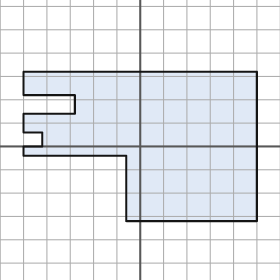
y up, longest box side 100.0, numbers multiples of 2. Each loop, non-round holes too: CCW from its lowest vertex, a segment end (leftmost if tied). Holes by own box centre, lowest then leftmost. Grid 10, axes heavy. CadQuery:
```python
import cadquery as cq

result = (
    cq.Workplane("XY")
    .moveTo(-6.0, -32.0)
    .lineTo(50.0, -32.0)
    .lineTo(50.0, 32.0)
    .lineTo(-50.0, 32.0)
    .lineTo(-50.0, 22.0)
    .lineTo(-28.0, 22.0)
    .lineTo(-28.0, 14.0)
    .lineTo(-50.0, 14.0)
    .lineTo(-50.0, 6.0)
    .lineTo(-42.0, 6.0)
    .lineTo(-42.0, 0.0)
    .lineTo(-50.0, 0.0)
    .lineTo(-50.0, -4.0)
    .lineTo(-6.0, -4.0)
    .close()
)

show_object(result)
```